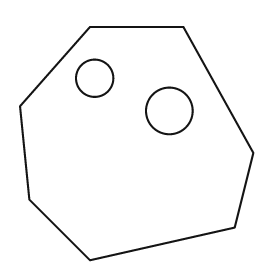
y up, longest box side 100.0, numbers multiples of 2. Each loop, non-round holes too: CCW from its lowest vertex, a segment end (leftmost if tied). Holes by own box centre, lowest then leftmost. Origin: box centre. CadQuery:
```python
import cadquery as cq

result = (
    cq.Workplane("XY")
    .moveTo(-20.0, -50.0)
    .lineTo(42.0, -36.0)
    .lineTo(50.0, -4.0)
    .lineTo(20.0, 50.0)
    .lineTo(-20.0, 50.0)
    .lineTo(-50.0, 16.0)
    .lineTo(-46.0, -24.0)
    .close()
    .moveTo(14.0, 14.0)
    .circle(10.0)
    .moveTo(-18.0, 28.0)
    .circle(8.0)
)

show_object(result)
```